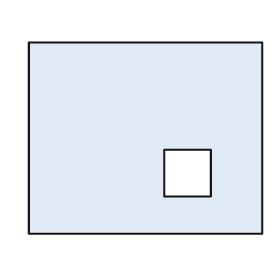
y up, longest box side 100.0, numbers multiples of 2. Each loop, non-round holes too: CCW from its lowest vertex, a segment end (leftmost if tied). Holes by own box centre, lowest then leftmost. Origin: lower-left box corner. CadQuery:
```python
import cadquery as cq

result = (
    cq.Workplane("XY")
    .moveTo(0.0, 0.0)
    .lineTo(100.0, 0.0)
    .lineTo(100.0, 82.0)
    .lineTo(0.0, 82.0)
    .close()
    .moveTo(58.0, 16.0)
    .lineTo(78.0, 16.0)
    .lineTo(78.0, 36.0)
    .lineTo(58.0, 36.0)
    .close()
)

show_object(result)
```